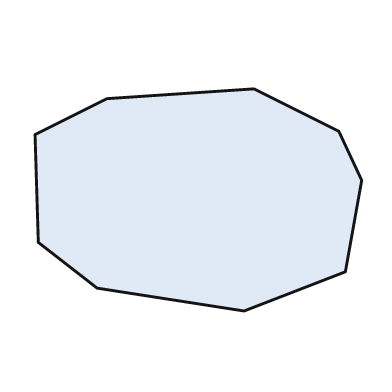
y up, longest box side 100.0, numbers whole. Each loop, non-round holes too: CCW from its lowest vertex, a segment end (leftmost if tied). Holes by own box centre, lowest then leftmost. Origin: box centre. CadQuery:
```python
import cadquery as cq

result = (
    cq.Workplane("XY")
    .moveTo(14.0, -34.0)
    .lineTo(45.0, -22.0)
    .lineTo(50.0, 6.0)
    .lineTo(43.0, 21.0)
    .lineTo(17.0, 34.0)
    .lineTo(-28.0, 31.0)
    .lineTo(-50.0, 20.0)
    .lineTo(-49.0, -13.0)
    .lineTo(-31.0, -27.0)
    .close()
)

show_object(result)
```